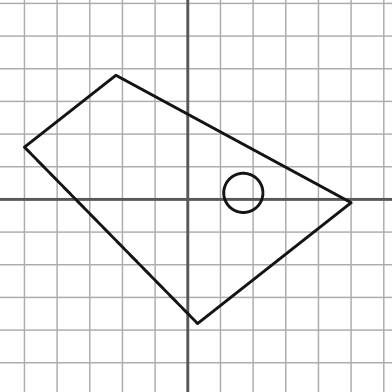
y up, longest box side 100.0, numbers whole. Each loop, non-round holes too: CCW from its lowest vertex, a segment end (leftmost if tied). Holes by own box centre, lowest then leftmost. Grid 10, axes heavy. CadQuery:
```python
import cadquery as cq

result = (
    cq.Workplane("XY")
    .moveTo(3.0, -38.0)
    .lineTo(50.0, -1.0)
    .lineTo(-22.0, 38.0)
    .lineTo(-50.0, 16.0)
    .close()
    .moveTo(17.0, 2.0)
    .circle(6.0)
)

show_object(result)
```